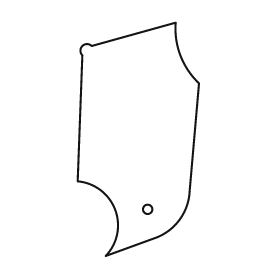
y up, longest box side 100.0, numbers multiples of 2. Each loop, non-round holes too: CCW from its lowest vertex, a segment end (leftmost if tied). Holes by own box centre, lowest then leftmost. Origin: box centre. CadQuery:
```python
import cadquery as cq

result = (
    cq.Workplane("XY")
    .moveTo(-14.0, -50.0)
    .lineTo(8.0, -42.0)
    .threePointArc((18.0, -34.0), (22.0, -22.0))
    .lineTo(26.0, 24.0)
    .threePointArc((18.0, 36.0), (16.0, 50.0))
    .lineTo(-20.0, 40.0)
    .threePointArc((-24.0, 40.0), (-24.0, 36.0))
    .lineTo(-26.0, -18.0)
    .threePointArc((-10.0, -30.0), (-14.0, -50.0))
    .close()
    .moveTo(4.0, -30.0)
    .circle(2.0)
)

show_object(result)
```